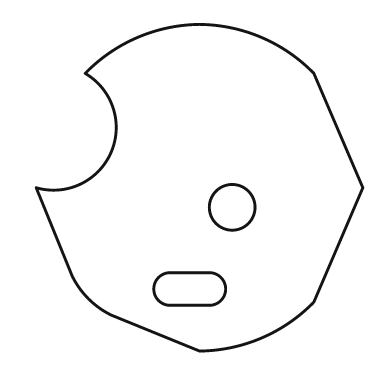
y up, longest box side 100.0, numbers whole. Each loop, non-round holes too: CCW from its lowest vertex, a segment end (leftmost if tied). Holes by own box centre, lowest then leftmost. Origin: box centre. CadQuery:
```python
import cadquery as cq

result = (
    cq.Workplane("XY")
    .moveTo(0.0, -50.0)
    .threePointArc((19.0, -46.0), (35.0, -35.0))
    .lineTo(50.0, 0.0)
    .lineTo(35.0, 35.0)
    .threePointArc((19.0, 46.0), (0.0, 50.0))
    .threePointArc((-19.0, 46.0), (-35.0, 35.0))
    .threePointArc((-27.0, 11.0), (-50.0, 0.0))
    .lineTo(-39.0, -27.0)
    .threePointArc((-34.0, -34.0), (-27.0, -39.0))
    .close()
    .moveTo(-9.0, -36.0)
    .lineTo(3.0, -36.0)
    .threePointArc((8.0, -31.0), (3.0, -26.0))
    .lineTo(-9.0, -26.0)
    .threePointArc((-14.0, -31.0), (-9.0, -36.0))
    .close()
    .moveTo(10.0, -6.0)
    .circle(7.0)
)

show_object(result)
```